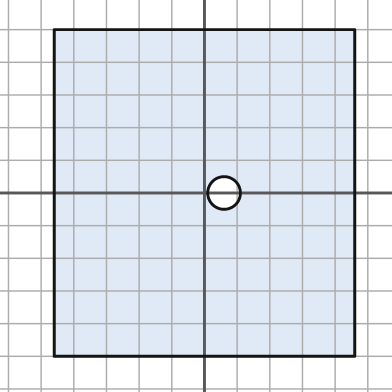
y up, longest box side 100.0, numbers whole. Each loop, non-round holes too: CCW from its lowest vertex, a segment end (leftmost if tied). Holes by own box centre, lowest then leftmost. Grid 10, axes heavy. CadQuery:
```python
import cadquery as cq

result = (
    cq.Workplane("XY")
    .moveTo(-46.0, -50.0)
    .lineTo(46.0, -50.0)
    .lineTo(46.0, 50.0)
    .lineTo(-46.0, 50.0)
    .close()
    .moveTo(6.0, 0.0)
    .circle(5.0)
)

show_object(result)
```